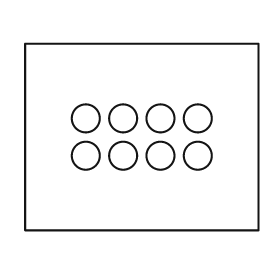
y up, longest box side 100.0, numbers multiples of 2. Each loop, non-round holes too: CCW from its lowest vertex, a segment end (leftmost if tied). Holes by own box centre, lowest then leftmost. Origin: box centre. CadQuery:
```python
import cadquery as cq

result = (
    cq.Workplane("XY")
    .moveTo(-50.0, -40.0)
    .lineTo(50.0, -40.0)
    .lineTo(50.0, 40.0)
    .lineTo(-50.0, 40.0)
    .close()
    .moveTo(-24.0, -8.0)
    .circle(6.0)
    .moveTo(-8.0, -8.0)
    .circle(6.0)
    .moveTo(8.0, -8.0)
    .circle(6.0)
    .moveTo(24.0, -8.0)
    .circle(6.0)
    .moveTo(-24.0, 8.0)
    .circle(6.0)
    .moveTo(-8.0, 8.0)
    .circle(6.0)
    .moveTo(8.0, 8.0)
    .circle(6.0)
    .moveTo(24.0, 8.0)
    .circle(6.0)
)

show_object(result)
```